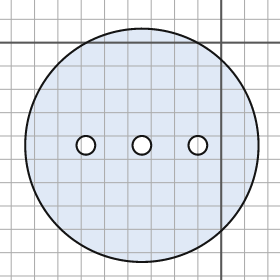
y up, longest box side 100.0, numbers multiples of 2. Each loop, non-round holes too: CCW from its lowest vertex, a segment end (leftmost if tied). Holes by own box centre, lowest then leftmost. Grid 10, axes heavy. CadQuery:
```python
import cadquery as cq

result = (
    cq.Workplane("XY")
    .moveTo(-34.0, -44.0)
    .circle(50.0)
    .moveTo(-58.0, -44.0)
    .circle(4.0)
    .moveTo(-34.0, -44.0)
    .circle(4.0)
    .moveTo(-10.0, -44.0)
    .circle(4.0)
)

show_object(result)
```